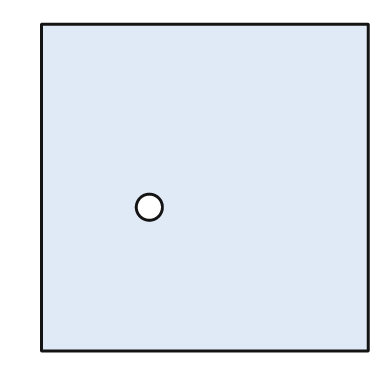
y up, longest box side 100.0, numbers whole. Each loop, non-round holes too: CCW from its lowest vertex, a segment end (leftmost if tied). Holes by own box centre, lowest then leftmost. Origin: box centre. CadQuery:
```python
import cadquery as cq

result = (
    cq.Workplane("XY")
    .moveTo(-50.0, -50.0)
    .lineTo(50.0, -50.0)
    .lineTo(50.0, 50.0)
    .lineTo(-50.0, 50.0)
    .close()
    .moveTo(-17.0, -6.0)
    .circle(4.0)
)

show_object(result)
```